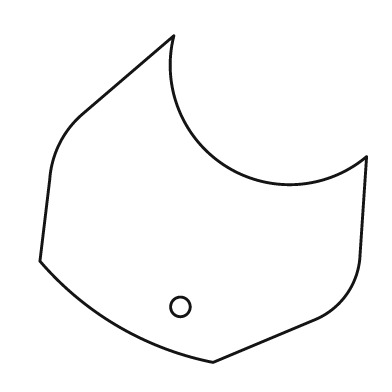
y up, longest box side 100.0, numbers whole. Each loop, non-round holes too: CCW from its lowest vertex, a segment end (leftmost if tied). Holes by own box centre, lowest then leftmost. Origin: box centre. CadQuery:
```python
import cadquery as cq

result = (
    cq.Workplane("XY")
    .moveTo(3.0, -50.0)
    .lineTo(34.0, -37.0)
    .threePointArc((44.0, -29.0), (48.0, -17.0))
    .lineTo(50.0, 13.0)
    .threePointArc((7.0, 10.0), (-9.0, 50.0))
    .lineTo(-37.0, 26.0)
    .threePointArc((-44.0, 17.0), (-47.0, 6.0))
    .lineTo(-50.0, -19.0)
    .threePointArc((-26.0, -39.0), (3.0, -50.0))
    .close()
    .moveTo(-7.0, -33.0)
    .circle(3.0)
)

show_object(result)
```